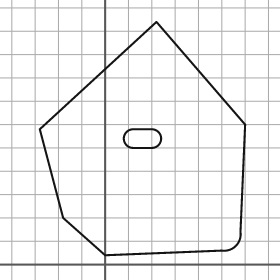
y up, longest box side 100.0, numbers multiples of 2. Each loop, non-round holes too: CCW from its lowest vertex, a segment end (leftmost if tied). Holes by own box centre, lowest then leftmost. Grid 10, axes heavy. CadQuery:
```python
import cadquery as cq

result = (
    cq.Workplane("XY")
    .moveTo(0.0, 4.0)
    .lineTo(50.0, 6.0)
    .threePointArc((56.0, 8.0), (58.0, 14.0))
    .lineTo(60.0, 60.0)
    .lineTo(22.0, 104.0)
    .lineTo(-28.0, 58.0)
    .lineTo(-18.0, 20.0)
    .close()
    .moveTo(12.0, 50.0)
    .lineTo(20.0, 50.0)
    .threePointArc((24.0, 54.0), (20.0, 58.0))
    .lineTo(12.0, 58.0)
    .threePointArc((8.0, 54.0), (12.0, 50.0))
    .close()
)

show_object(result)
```